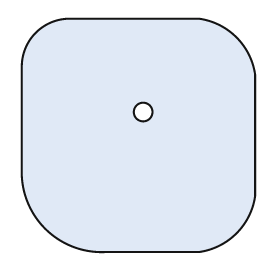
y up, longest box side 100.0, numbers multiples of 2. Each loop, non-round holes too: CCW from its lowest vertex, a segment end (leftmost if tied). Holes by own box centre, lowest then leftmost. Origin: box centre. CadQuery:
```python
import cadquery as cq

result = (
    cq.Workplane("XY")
    .moveTo(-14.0, -50.0)
    .lineTo(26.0, -50.0)
    .threePointArc((42.0, -42.0), (50.0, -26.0))
    .lineTo(50.0, 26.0)
    .threePointArc((42.0, 42.0), (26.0, 50.0))
    .lineTo(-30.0, 50.0)
    .threePointArc((-44.0, 44.0), (-50.0, 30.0))
    .lineTo(-50.0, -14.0)
    .threePointArc((-40.0, -40.0), (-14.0, -50.0))
    .close()
    .moveTo(2.0, 10.0)
    .circle(4.0)
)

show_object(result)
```